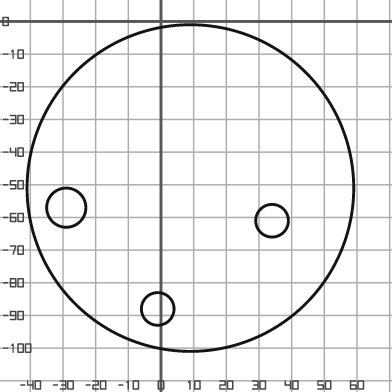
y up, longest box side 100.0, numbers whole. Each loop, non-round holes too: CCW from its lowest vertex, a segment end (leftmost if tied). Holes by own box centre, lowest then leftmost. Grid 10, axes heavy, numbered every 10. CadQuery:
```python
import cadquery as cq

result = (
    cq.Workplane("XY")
    .moveTo(9.0, -51.0)
    .circle(50.0)
    .moveTo(-1.0, -88.0)
    .circle(5.0)
    .moveTo(34.0, -61.0)
    .circle(5.0)
    .moveTo(-29.0, -57.0)
    .circle(6.0)
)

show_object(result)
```